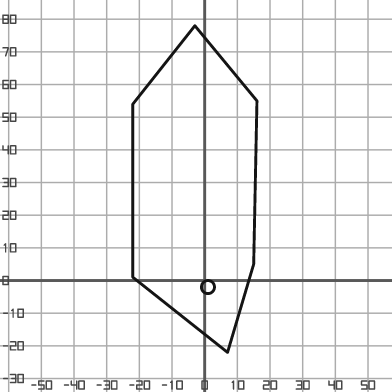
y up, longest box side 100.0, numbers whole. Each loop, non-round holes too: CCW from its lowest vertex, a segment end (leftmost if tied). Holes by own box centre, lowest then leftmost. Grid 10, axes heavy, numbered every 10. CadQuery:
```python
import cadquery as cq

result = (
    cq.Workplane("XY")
    .moveTo(7.0, -22.0)
    .lineTo(15.0, 5.0)
    .lineTo(16.0, 55.0)
    .lineTo(-3.0, 78.0)
    .lineTo(-22.0, 54.0)
    .lineTo(-22.0, 1.0)
    .close()
    .moveTo(1.0, -2.0)
    .circle(2.0)
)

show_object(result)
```